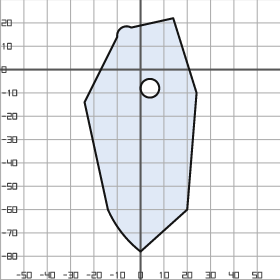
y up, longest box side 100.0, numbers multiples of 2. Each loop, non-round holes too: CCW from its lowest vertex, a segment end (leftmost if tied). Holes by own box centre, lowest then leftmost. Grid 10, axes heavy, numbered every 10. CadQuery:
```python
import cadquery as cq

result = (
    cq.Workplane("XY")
    .moveTo(0.0, -78.0)
    .lineTo(20.0, -60.0)
    .lineTo(24.0, -10.0)
    .lineTo(14.0, 22.0)
    .lineTo(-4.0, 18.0)
    .threePointArc((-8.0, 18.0), (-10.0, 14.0))
    .lineTo(-24.0, -14.0)
    .lineTo(-14.0, -60.0)
    .threePointArc((-8.0, -70.0), (0.0, -78.0))
    .close()
    .moveTo(4.0, -8.0)
    .circle(4.0)
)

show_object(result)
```